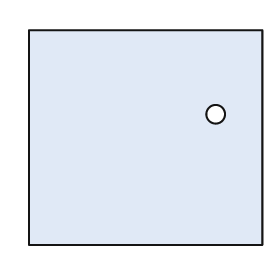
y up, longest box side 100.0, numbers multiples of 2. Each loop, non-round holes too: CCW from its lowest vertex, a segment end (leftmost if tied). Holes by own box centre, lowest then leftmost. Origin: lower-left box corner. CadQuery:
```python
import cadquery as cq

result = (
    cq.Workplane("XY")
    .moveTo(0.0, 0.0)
    .lineTo(100.0, 0.0)
    .lineTo(100.0, 92.0)
    .lineTo(0.0, 92.0)
    .close()
    .moveTo(80.0, 56.0)
    .circle(4.0)
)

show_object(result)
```